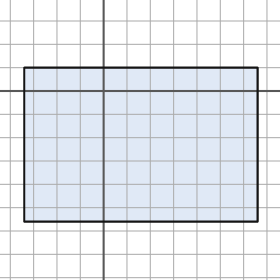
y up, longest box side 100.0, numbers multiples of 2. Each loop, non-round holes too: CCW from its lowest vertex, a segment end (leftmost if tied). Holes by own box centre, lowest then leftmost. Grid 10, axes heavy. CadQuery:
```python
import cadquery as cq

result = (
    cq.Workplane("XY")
    .moveTo(-34.0, -56.0)
    .lineTo(66.0, -56.0)
    .lineTo(66.0, 10.0)
    .lineTo(-34.0, 10.0)
    .close()
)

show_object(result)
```